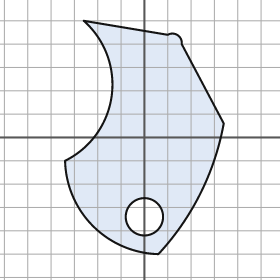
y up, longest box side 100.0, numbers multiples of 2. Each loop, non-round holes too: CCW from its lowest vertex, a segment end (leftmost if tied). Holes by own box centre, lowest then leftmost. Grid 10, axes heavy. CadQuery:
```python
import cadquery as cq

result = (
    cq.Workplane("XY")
    .moveTo(6.0, -50.0)
    .threePointArc((24.0, -24.0), (34.0, 6.0))
    .lineTo(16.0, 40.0)
    .threePointArc((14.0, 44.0), (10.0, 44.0))
    .lineTo(-26.0, 50.0)
    .threePointArc((-14.0, 18.0), (-34.0, -10.0))
    .threePointArc((-22.0, -38.0), (6.0, -50.0))
    .close()
    .moveTo(0.0, -34.0)
    .circle(8.0)
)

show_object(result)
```